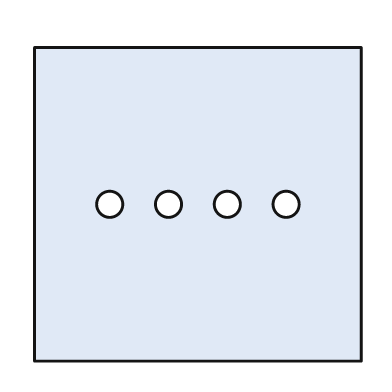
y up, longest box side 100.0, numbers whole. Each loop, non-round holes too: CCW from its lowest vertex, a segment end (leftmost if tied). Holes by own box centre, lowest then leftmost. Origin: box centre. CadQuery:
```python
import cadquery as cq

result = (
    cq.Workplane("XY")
    .moveTo(-50.0, -48.0)
    .lineTo(50.0, -48.0)
    .lineTo(50.0, 48.0)
    .lineTo(-50.0, 48.0)
    .close()
    .moveTo(-27.0, 0.0)
    .circle(4.0)
    .moveTo(-9.0, 0.0)
    .circle(4.0)
    .moveTo(9.0, 0.0)
    .circle(4.0)
    .moveTo(27.0, 0.0)
    .circle(4.0)
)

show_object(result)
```